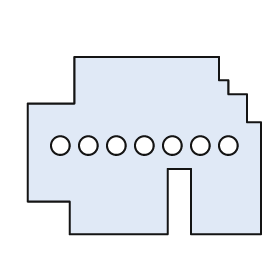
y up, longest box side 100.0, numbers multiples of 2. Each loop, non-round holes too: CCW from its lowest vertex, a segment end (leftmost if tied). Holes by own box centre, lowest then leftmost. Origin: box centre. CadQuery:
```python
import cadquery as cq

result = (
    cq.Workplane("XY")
    .moveTo(-32.0, -38.0)
    .lineTo(10.0, -38.0)
    .lineTo(10.0, -10.0)
    .lineTo(20.0, -10.0)
    .lineTo(20.0, -38.0)
    .lineTo(50.0, -38.0)
    .lineTo(50.0, 10.0)
    .lineTo(44.0, 10.0)
    .lineTo(44.0, 22.0)
    .lineTo(36.0, 22.0)
    .lineTo(36.0, 28.0)
    .lineTo(32.0, 28.0)
    .lineTo(32.0, 38.0)
    .lineTo(-30.0, 38.0)
    .lineTo(-30.0, 18.0)
    .lineTo(-50.0, 18.0)
    .lineTo(-50.0, -24.0)
    .lineTo(-32.0, -24.0)
    .close()
    .moveTo(-36.0, 0.0)
    .circle(4.0)
    .moveTo(-24.0, 0.0)
    .circle(4.0)
    .moveTo(-12.0, 0.0)
    .circle(4.0)
    .moveTo(0.0, 0.0)
    .circle(4.0)
    .moveTo(12.0, 0.0)
    .circle(4.0)
    .moveTo(24.0, 0.0)
    .circle(4.0)
    .moveTo(36.0, 0.0)
    .circle(4.0)
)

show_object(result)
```